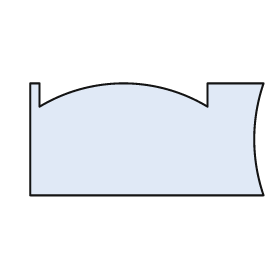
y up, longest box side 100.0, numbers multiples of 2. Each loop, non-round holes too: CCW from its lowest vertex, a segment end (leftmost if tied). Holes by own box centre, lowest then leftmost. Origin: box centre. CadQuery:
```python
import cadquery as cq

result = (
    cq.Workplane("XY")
    .moveTo(-50.0, -24.0)
    .lineTo(50.0, -24.0)
    .threePointArc((46.0, 0.0), (50.0, 24.0))
    .lineTo(26.0, 24.0)
    .lineTo(26.0, 14.0)
    .threePointArc((-10.0, 24.0), (-46.0, 14.0))
    .lineTo(-46.0, 24.0)
    .lineTo(-50.0, 24.0)
    .close()
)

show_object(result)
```